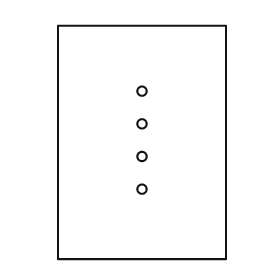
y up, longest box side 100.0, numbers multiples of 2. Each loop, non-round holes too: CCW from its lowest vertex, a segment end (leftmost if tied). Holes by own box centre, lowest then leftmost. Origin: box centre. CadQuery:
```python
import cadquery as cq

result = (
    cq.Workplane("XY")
    .moveTo(-36.0, -50.0)
    .lineTo(36.0, -50.0)
    .lineTo(36.0, 50.0)
    .lineTo(-36.0, 50.0)
    .close()
    .moveTo(0.0, -20.0)
    .circle(2.0)
    .moveTo(0.0, -6.0)
    .circle(2.0)
    .moveTo(0.0, 8.0)
    .circle(2.0)
    .moveTo(0.0, 22.0)
    .circle(2.0)
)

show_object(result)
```